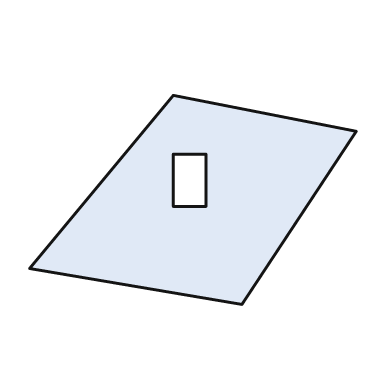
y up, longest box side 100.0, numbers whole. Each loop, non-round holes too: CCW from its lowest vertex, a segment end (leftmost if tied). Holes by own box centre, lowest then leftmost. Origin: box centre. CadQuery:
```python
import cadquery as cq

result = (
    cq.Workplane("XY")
    .moveTo(15.0, -32.0)
    .lineTo(50.0, 21.0)
    .lineTo(-6.0, 32.0)
    .lineTo(-50.0, -21.0)
    .close()
    .moveTo(-6.0, -2.0)
    .lineTo(4.0, -2.0)
    .lineTo(4.0, 14.0)
    .lineTo(-6.0, 14.0)
    .close()
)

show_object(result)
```